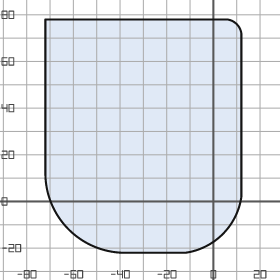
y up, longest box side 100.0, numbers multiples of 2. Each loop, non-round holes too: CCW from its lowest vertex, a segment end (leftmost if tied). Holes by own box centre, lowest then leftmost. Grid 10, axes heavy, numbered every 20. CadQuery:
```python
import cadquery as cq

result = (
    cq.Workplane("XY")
    .moveTo(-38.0, -22.0)
    .lineTo(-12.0, -22.0)
    .threePointArc((4.0, -14.0), (12.0, 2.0))
    .lineTo(12.0, 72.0)
    .threePointArc((10.0, 76.0), (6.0, 78.0))
    .lineTo(-72.0, 78.0)
    .lineTo(-72.0, 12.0)
    .threePointArc((-62.0, -12.0), (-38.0, -22.0))
    .close()
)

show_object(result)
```